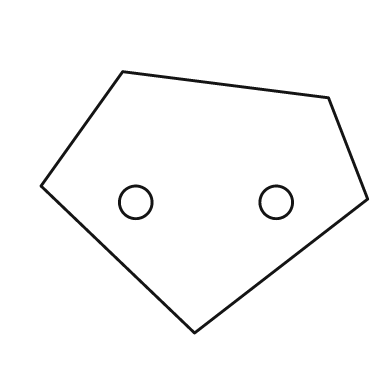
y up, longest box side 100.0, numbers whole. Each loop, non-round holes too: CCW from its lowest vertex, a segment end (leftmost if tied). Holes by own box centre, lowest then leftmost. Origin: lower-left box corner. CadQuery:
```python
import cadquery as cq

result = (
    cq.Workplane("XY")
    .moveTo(47.0, 0.0)
    .lineTo(100.0, 41.0)
    .lineTo(88.0, 72.0)
    .lineTo(25.0, 80.0)
    .lineTo(0.0, 45.0)
    .close()
    .moveTo(29.0, 40.0)
    .circle(5.0)
    .moveTo(72.0, 40.0)
    .circle(5.0)
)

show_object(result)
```